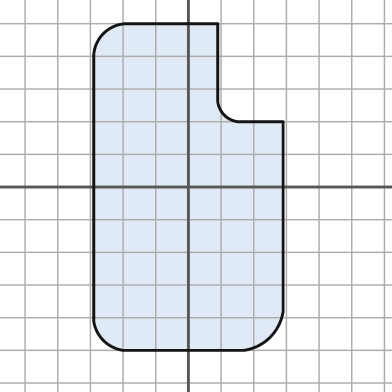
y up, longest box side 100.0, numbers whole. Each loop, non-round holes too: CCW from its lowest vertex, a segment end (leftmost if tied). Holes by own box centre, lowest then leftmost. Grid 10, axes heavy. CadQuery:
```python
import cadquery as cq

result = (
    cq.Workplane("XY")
    .moveTo(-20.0, -50.0)
    .lineTo(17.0, -50.0)
    .threePointArc((25.0, -46.0), (29.0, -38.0))
    .lineTo(29.0, 20.0)
    .lineTo(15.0, 20.0)
    .threePointArc((11.0, 22.0), (9.0, 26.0))
    .lineTo(9.0, 50.0)
    .lineTo(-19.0, 50.0)
    .threePointArc((-26.0, 47.0), (-29.0, 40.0))
    .lineTo(-29.0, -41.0)
    .threePointArc((-26.0, -47.0), (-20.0, -50.0))
    .close()
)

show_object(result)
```